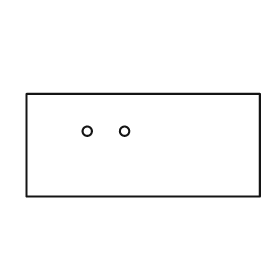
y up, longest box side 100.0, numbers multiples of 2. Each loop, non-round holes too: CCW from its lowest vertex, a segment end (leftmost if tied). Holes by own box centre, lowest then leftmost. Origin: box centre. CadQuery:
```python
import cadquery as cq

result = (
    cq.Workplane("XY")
    .moveTo(-50.0, -22.0)
    .lineTo(50.0, -22.0)
    .lineTo(50.0, 22.0)
    .lineTo(-50.0, 22.0)
    .close()
    .moveTo(-24.0, 6.0)
    .circle(2.0)
    .moveTo(-8.0, 6.0)
    .circle(2.0)
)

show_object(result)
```